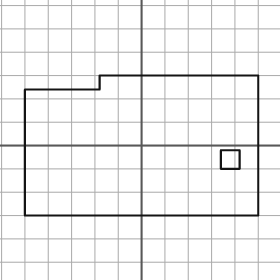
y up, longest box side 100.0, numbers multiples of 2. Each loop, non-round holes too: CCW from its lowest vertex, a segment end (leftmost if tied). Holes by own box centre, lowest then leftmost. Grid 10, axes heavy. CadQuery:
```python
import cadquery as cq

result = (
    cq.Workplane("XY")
    .moveTo(-50.0, -30.0)
    .lineTo(50.0, -30.0)
    .lineTo(50.0, 30.0)
    .lineTo(-18.0, 30.0)
    .lineTo(-18.0, 24.0)
    .lineTo(-50.0, 24.0)
    .close()
    .moveTo(34.0, -10.0)
    .lineTo(42.0, -10.0)
    .lineTo(42.0, -2.0)
    .lineTo(34.0, -2.0)
    .close()
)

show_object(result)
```